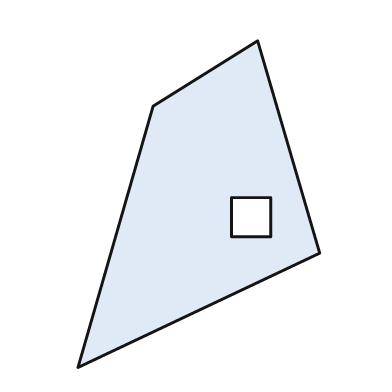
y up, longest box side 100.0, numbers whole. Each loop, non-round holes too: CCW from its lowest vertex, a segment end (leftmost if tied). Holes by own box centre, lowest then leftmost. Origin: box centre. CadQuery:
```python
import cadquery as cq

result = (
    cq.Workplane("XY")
    .moveTo(-37.0, -50.0)
    .lineTo(37.0, -15.0)
    .lineTo(18.0, 50.0)
    .lineTo(-14.0, 30.0)
    .close()
    .moveTo(10.0, -10.0)
    .lineTo(22.0, -10.0)
    .lineTo(22.0, 2.0)
    .lineTo(10.0, 2.0)
    .close()
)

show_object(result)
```